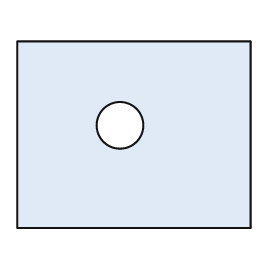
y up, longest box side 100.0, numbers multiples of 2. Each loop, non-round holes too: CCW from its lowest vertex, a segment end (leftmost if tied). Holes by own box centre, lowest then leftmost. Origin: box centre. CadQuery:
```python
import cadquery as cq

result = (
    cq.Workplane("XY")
    .moveTo(-50.0, -40.0)
    .lineTo(50.0, -40.0)
    .lineTo(50.0, 40.0)
    .lineTo(-50.0, 40.0)
    .close()
    .moveTo(-6.0, 4.0)
    .circle(10.0)
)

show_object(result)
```